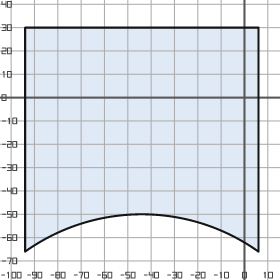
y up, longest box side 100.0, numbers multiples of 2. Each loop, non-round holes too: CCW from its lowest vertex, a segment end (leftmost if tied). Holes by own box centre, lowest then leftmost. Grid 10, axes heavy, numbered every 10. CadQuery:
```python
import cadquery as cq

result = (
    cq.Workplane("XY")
    .moveTo(-94.0, -66.0)
    .threePointArc((-44.0, -50.0), (6.0, -66.0))
    .lineTo(6.0, 30.0)
    .lineTo(-94.0, 30.0)
    .close()
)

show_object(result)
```